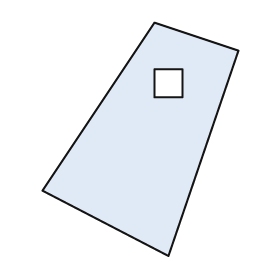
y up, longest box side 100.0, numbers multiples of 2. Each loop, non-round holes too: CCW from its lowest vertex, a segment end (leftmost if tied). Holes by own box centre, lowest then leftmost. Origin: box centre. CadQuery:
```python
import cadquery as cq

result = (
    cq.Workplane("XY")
    .moveTo(12.0, -50.0)
    .lineTo(42.0, 38.0)
    .lineTo(6.0, 50.0)
    .lineTo(-42.0, -22.0)
    .close()
    .moveTo(6.0, 18.0)
    .lineTo(18.0, 18.0)
    .lineTo(18.0, 30.0)
    .lineTo(6.0, 30.0)
    .close()
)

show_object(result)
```